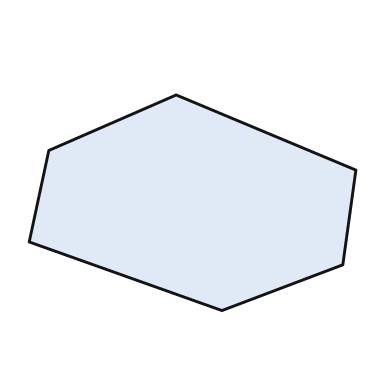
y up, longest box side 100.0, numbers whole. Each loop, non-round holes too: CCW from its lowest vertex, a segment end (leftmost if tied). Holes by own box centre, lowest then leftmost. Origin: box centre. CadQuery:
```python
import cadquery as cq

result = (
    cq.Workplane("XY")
    .moveTo(9.0, -33.0)
    .lineTo(46.0, -19.0)
    .lineTo(50.0, 10.0)
    .lineTo(-5.0, 33.0)
    .lineTo(-44.0, 16.0)
    .lineTo(-50.0, -12.0)
    .close()
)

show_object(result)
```